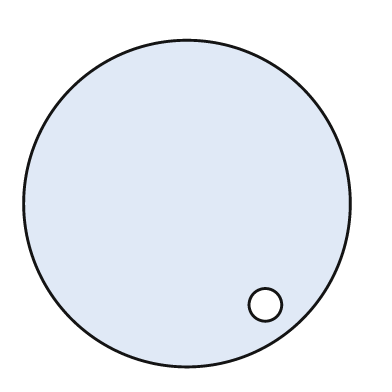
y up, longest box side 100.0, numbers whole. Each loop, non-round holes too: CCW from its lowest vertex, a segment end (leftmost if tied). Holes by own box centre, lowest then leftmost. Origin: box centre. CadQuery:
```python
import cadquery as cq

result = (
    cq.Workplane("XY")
    .moveTo(0.0, 0.0)
    .circle(50.0)
    .moveTo(24.0, -31.0)
    .circle(5.0)
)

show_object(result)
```